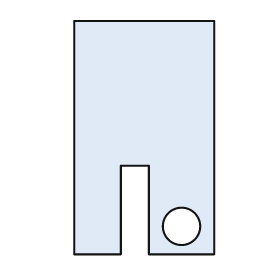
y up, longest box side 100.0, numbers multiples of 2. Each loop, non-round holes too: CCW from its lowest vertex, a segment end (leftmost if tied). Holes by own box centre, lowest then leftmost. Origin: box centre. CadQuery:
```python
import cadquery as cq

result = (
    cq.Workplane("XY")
    .moveTo(-30.0, -50.0)
    .lineTo(-10.0, -50.0)
    .lineTo(-10.0, -12.0)
    .lineTo(2.0, -12.0)
    .lineTo(2.0, -50.0)
    .lineTo(30.0, -50.0)
    .lineTo(30.0, 50.0)
    .lineTo(-30.0, 50.0)
    .close()
    .moveTo(16.0, -38.0)
    .circle(8.0)
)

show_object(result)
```